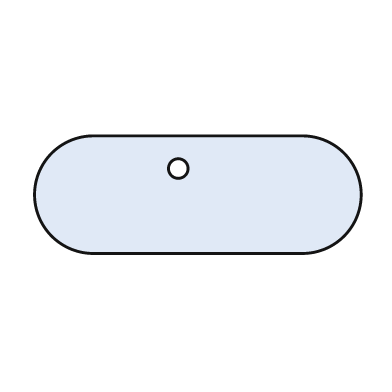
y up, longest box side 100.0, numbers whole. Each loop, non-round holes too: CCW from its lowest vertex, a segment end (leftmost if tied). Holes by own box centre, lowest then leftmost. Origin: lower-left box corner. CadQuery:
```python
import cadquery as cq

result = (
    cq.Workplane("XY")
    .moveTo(18.0, 0.0)
    .lineTo(82.0, 0.0)
    .threePointArc((100.0, 18.0), (82.0, 36.0))
    .lineTo(18.0, 36.0)
    .threePointArc((0.0, 18.0), (18.0, 0.0))
    .close()
    .moveTo(44.0, 26.0)
    .circle(3.0)
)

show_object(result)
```